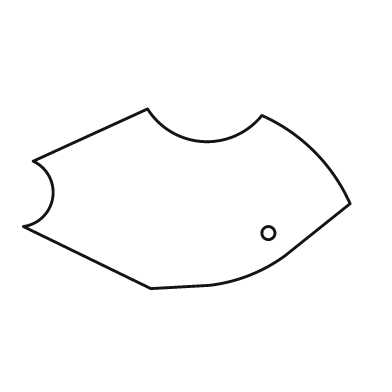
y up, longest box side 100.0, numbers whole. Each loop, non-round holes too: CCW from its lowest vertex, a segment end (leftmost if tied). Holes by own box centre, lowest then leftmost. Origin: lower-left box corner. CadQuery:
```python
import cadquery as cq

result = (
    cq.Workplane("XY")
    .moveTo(39.0, 0.0)
    .lineTo(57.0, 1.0)
    .threePointArc((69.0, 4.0), (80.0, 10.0))
    .lineTo(100.0, 26.0)
    .threePointArc((89.0, 42.0), (73.0, 53.0))
    .threePointArc((55.0, 45.0), (38.0, 55.0))
    .lineTo(3.0, 39.0)
    .threePointArc((9.0, 28.0), (0.0, 19.0))
    .close()
    .moveTo(75.0, 17.0)
    .circle(2.0)
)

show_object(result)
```